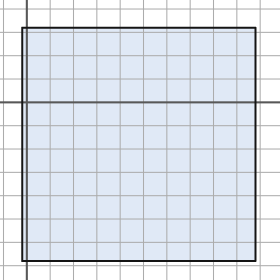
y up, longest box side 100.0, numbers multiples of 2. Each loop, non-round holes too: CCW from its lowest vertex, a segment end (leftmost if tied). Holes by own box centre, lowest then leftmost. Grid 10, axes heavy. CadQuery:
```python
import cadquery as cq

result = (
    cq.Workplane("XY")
    .moveTo(-2.0, -68.0)
    .lineTo(98.0, -68.0)
    .lineTo(98.0, 32.0)
    .lineTo(-2.0, 32.0)
    .close()
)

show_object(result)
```